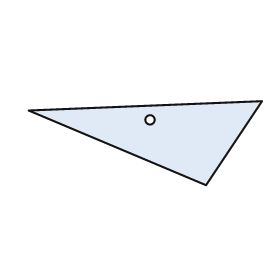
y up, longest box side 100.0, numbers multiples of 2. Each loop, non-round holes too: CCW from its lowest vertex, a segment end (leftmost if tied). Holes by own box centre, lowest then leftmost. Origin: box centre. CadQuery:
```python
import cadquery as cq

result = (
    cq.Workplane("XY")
    .moveTo(26.0, -18.0)
    .lineTo(50.0, 18.0)
    .lineTo(-50.0, 14.0)
    .close()
    .moveTo(2.0, 10.0)
    .circle(2.0)
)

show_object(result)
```